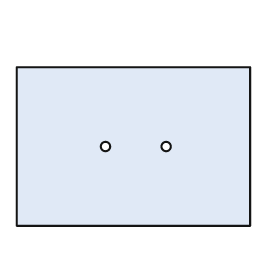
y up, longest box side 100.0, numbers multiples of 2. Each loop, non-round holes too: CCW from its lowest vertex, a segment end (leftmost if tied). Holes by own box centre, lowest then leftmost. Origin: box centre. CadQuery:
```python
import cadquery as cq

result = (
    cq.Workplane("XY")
    .moveTo(-50.0, -34.0)
    .lineTo(50.0, -34.0)
    .lineTo(50.0, 34.0)
    .lineTo(-50.0, 34.0)
    .close()
    .moveTo(-12.0, 0.0)
    .circle(2.0)
    .moveTo(14.0, 0.0)
    .circle(2.0)
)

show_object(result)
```